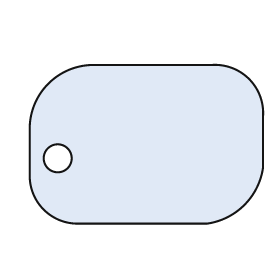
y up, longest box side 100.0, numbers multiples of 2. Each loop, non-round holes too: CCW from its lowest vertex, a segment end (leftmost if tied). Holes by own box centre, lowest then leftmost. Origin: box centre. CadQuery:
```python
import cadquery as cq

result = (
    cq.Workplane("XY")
    .moveTo(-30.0, -34.0)
    .lineTo(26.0, -34.0)
    .threePointArc((42.0, -26.0), (50.0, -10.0))
    .lineTo(50.0, 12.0)
    .threePointArc((44.0, 28.0), (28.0, 34.0))
    .lineTo(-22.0, 34.0)
    .threePointArc((-42.0, 26.0), (-50.0, 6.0))
    .lineTo(-50.0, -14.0)
    .threePointArc((-44.0, -28.0), (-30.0, -34.0))
    .close()
    .moveTo(-38.0, -6.0)
    .circle(6.0)
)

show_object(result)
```